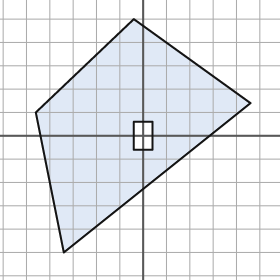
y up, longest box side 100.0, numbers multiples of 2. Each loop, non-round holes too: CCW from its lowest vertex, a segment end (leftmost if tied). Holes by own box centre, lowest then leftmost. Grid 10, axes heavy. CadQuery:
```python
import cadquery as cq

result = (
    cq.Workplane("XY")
    .moveTo(-34.0, -50.0)
    .lineTo(46.0, 14.0)
    .lineTo(-4.0, 50.0)
    .lineTo(-46.0, 10.0)
    .close()
    .moveTo(-4.0, -6.0)
    .lineTo(4.0, -6.0)
    .lineTo(4.0, 6.0)
    .lineTo(-4.0, 6.0)
    .close()
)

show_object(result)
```